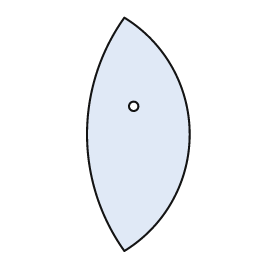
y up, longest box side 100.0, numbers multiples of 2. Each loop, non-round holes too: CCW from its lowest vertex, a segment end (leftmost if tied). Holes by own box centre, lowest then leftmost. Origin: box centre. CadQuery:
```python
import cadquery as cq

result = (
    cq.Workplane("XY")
    .moveTo(-6.0, -50.0)
    .threePointArc((22.0, 0.0), (-6.0, 50.0))
    .threePointArc((-22.0, 0.0), (-6.0, -50.0))
    .close()
    .moveTo(-2.0, 12.0)
    .circle(2.0)
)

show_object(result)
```